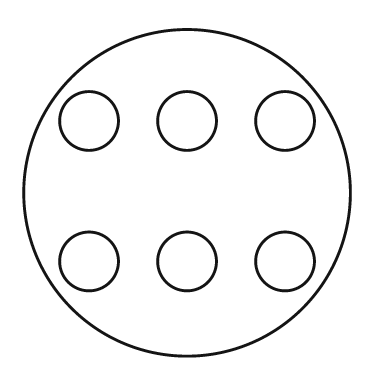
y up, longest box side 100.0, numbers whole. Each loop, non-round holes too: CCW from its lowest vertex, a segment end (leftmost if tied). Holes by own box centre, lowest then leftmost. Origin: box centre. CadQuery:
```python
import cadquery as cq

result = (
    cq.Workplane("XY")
    .moveTo(0.0, 0.0)
    .circle(50.0)
    .moveTo(-30.0, -21.0)
    .circle(9.0)
    .moveTo(0.0, -21.0)
    .circle(9.0)
    .moveTo(30.0, -21.0)
    .circle(9.0)
    .moveTo(-30.0, 22.0)
    .circle(9.0)
    .moveTo(0.0, 22.0)
    .circle(9.0)
    .moveTo(30.0, 22.0)
    .circle(9.0)
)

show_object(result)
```